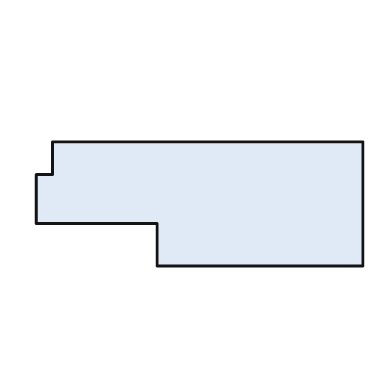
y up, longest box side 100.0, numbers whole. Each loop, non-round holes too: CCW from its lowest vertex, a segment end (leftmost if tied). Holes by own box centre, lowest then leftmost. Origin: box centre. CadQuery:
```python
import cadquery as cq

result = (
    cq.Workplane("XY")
    .moveTo(-13.0, -19.0)
    .lineTo(50.0, -19.0)
    .lineTo(50.0, 19.0)
    .lineTo(-45.0, 19.0)
    .lineTo(-45.0, 9.0)
    .lineTo(-50.0, 9.0)
    .lineTo(-50.0, -6.0)
    .lineTo(-13.0, -6.0)
    .close()
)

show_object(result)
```